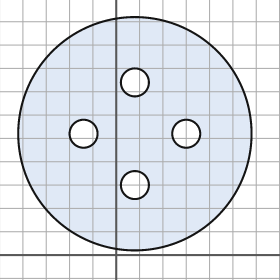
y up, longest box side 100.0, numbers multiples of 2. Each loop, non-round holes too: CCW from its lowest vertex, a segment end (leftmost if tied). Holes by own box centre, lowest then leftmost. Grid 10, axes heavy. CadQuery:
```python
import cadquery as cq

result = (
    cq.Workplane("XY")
    .moveTo(8.0, 52.0)
    .circle(50.0)
    .moveTo(8.0, 30.0)
    .circle(6.0)
    .moveTo(-14.0, 52.0)
    .circle(6.0)
    .moveTo(30.0, 52.0)
    .circle(6.0)
    .moveTo(8.0, 74.0)
    .circle(6.0)
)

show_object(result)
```